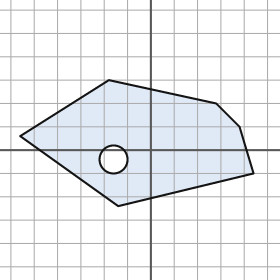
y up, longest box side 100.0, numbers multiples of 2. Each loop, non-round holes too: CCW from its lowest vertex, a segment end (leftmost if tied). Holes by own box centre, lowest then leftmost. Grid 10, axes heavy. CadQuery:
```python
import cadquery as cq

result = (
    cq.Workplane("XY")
    .moveTo(-14.0, -24.0)
    .lineTo(44.0, -10.0)
    .lineTo(38.0, 10.0)
    .lineTo(28.0, 20.0)
    .lineTo(-18.0, 30.0)
    .lineTo(-56.0, 6.0)
    .close()
    .moveTo(-16.0, -4.0)
    .circle(6.0)
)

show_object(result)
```